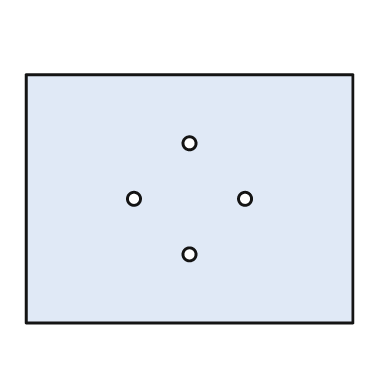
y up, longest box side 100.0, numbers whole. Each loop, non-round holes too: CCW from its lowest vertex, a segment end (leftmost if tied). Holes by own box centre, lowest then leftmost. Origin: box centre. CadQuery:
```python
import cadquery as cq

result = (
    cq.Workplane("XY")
    .moveTo(-50.0, -38.0)
    .lineTo(50.0, -38.0)
    .lineTo(50.0, 38.0)
    .lineTo(-50.0, 38.0)
    .close()
    .moveTo(0.0, -17.0)
    .circle(2.0)
    .moveTo(-17.0, 0.0)
    .circle(2.0)
    .moveTo(17.0, 0.0)
    .circle(2.0)
    .moveTo(0.0, 17.0)
    .circle(2.0)
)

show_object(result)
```